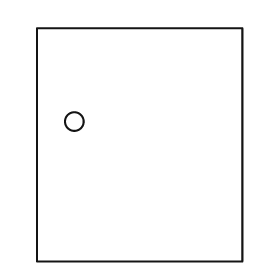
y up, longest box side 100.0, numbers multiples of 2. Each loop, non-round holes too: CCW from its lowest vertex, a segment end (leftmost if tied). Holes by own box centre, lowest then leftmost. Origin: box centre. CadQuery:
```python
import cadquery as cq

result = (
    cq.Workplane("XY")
    .moveTo(-44.0, -50.0)
    .lineTo(44.0, -50.0)
    .lineTo(44.0, 50.0)
    .lineTo(-44.0, 50.0)
    .close()
    .moveTo(-28.0, 10.0)
    .circle(4.0)
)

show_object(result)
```